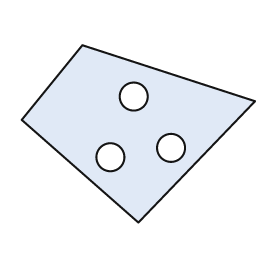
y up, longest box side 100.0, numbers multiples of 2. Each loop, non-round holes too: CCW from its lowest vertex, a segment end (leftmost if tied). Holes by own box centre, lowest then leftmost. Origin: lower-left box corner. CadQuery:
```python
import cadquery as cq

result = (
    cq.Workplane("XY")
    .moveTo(50.0, 0.0)
    .lineTo(100.0, 52.0)
    .lineTo(26.0, 76.0)
    .lineTo(0.0, 44.0)
    .close()
    .moveTo(38.0, 28.0)
    .circle(6.0)
    .moveTo(64.0, 32.0)
    .circle(6.0)
    .moveTo(48.0, 54.0)
    .circle(6.0)
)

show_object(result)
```